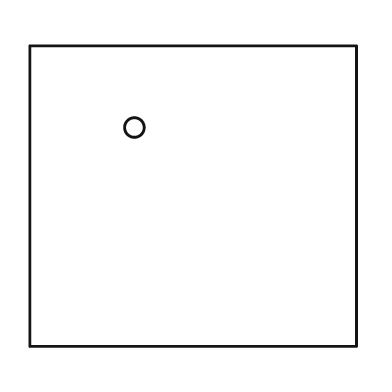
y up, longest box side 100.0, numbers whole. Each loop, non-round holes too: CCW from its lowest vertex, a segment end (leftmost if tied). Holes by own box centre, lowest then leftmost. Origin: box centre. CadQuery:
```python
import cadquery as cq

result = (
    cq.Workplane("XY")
    .moveTo(-50.0, -46.0)
    .lineTo(50.0, -46.0)
    .lineTo(50.0, 46.0)
    .lineTo(-50.0, 46.0)
    .close()
    .moveTo(-18.0, 21.0)
    .circle(3.0)
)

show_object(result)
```